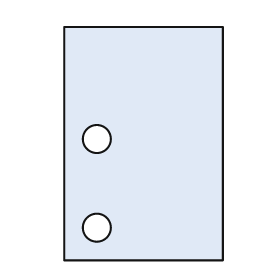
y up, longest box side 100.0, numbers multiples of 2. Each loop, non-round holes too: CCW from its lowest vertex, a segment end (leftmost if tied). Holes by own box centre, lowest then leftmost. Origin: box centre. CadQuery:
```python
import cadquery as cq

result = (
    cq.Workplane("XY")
    .moveTo(-34.0, -50.0)
    .lineTo(34.0, -50.0)
    .lineTo(34.0, 50.0)
    .lineTo(-34.0, 50.0)
    .close()
    .moveTo(-20.0, -36.0)
    .circle(6.0)
    .moveTo(-20.0, 2.0)
    .circle(6.0)
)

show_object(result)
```